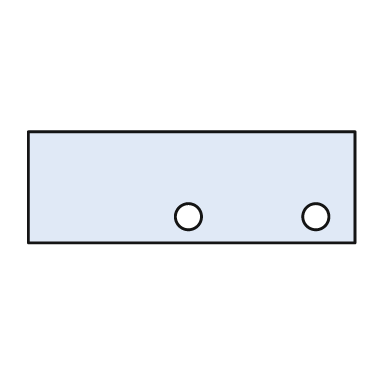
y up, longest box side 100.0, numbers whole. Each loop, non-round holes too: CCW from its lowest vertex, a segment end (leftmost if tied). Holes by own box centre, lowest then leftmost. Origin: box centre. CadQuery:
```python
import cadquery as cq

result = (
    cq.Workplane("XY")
    .moveTo(-50.0, -17.0)
    .lineTo(50.0, -17.0)
    .lineTo(50.0, 17.0)
    .lineTo(-50.0, 17.0)
    .close()
    .moveTo(-1.0, -9.0)
    .circle(4.0)
    .moveTo(38.0, -9.0)
    .circle(4.0)
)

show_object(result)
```